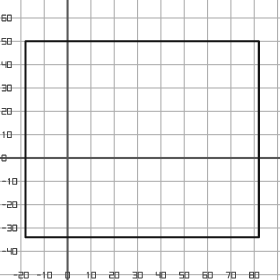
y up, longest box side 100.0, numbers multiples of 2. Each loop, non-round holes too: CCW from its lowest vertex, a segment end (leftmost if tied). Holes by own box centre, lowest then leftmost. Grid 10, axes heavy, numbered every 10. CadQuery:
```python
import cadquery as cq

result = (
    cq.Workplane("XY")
    .moveTo(-18.0, -34.0)
    .lineTo(82.0, -34.0)
    .lineTo(82.0, 50.0)
    .lineTo(-18.0, 50.0)
    .close()
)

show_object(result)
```